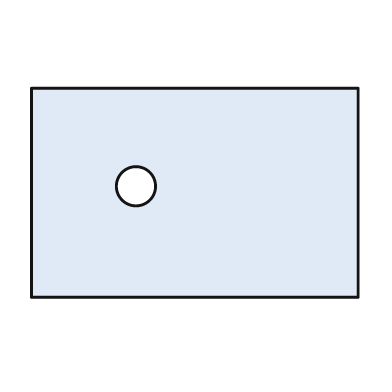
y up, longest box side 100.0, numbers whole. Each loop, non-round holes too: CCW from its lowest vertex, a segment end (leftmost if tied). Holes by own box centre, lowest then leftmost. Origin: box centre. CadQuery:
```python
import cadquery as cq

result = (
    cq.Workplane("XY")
    .moveTo(-50.0, -32.0)
    .lineTo(50.0, -32.0)
    .lineTo(50.0, 32.0)
    .lineTo(-50.0, 32.0)
    .close()
    .moveTo(-18.0, 2.0)
    .circle(6.0)
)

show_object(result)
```